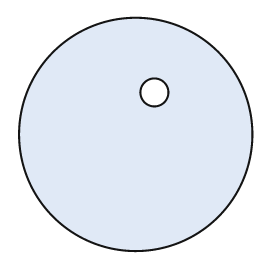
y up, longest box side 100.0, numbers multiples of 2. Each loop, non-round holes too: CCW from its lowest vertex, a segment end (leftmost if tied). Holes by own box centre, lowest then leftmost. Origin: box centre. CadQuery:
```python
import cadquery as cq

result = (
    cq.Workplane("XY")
    .moveTo(0.0, 0.0)
    .circle(50.0)
    .moveTo(8.0, 18.0)
    .circle(6.0)
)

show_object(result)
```